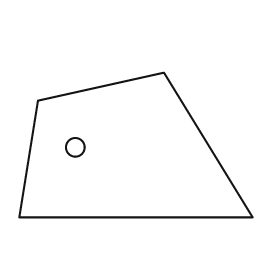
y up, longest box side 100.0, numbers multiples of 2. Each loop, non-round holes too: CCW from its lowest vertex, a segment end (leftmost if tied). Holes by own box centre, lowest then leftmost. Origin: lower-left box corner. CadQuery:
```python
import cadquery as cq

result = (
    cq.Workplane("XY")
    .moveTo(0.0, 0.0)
    .lineTo(100.0, 0.0)
    .lineTo(62.0, 62.0)
    .lineTo(8.0, 50.0)
    .close()
    .moveTo(24.0, 30.0)
    .circle(4.0)
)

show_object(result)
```